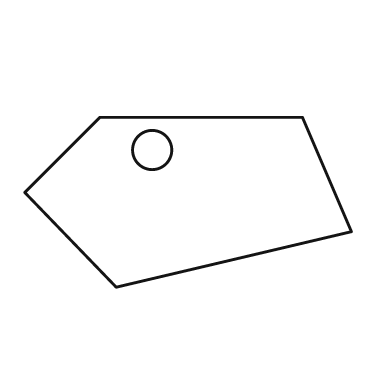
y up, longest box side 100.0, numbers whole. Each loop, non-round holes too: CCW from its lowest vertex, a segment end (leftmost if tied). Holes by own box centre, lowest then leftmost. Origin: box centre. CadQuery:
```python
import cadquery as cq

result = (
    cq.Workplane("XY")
    .moveTo(-22.0, -26.0)
    .lineTo(50.0, -9.0)
    .lineTo(35.0, 26.0)
    .lineTo(-27.0, 26.0)
    .lineTo(-50.0, 3.0)
    .close()
    .moveTo(-11.0, 16.0)
    .circle(6.0)
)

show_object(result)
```